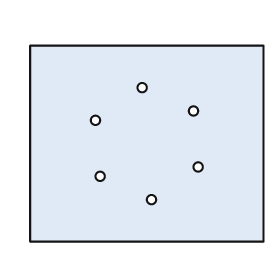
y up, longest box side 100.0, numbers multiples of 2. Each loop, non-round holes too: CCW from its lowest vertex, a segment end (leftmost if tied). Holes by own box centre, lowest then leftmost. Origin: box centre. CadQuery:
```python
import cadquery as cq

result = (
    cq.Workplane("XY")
    .moveTo(-50.0, -42.0)
    .lineTo(50.0, -42.0)
    .lineTo(50.0, 42.0)
    .lineTo(-50.0, 42.0)
    .close()
    .moveTo(2.0, -24.0)
    .circle(2.0)
    .moveTo(-20.0, -14.0)
    .circle(2.0)
    .moveTo(22.0, -10.0)
    .circle(2.0)
    .moveTo(-22.0, 10.0)
    .circle(2.0)
    .moveTo(20.0, 14.0)
    .circle(2.0)
    .moveTo(-2.0, 24.0)
    .circle(2.0)
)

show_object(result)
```